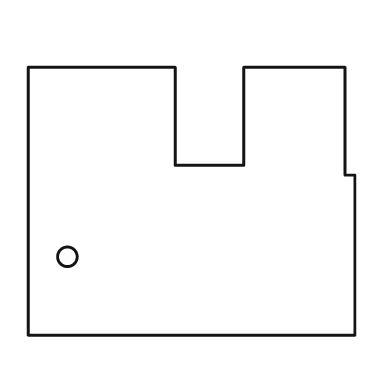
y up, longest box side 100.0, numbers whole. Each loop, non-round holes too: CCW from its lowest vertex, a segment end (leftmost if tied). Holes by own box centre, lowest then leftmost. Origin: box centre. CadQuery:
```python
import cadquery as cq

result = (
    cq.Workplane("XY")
    .moveTo(-50.0, -41.0)
    .lineTo(50.0, -41.0)
    .lineTo(50.0, 8.0)
    .lineTo(47.0, 8.0)
    .lineTo(47.0, 41.0)
    .lineTo(16.0, 41.0)
    .lineTo(16.0, 11.0)
    .lineTo(-5.0, 11.0)
    .lineTo(-5.0, 41.0)
    .lineTo(-50.0, 41.0)
    .close()
    .moveTo(-38.0, -17.0)
    .circle(3.0)
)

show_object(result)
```